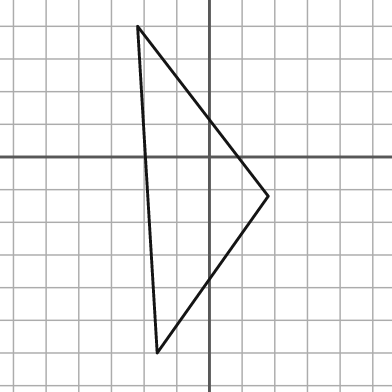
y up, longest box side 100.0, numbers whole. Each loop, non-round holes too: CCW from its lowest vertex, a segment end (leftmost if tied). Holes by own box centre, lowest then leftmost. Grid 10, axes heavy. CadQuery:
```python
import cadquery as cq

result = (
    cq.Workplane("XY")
    .moveTo(-16.0, -60.0)
    .lineTo(18.0, -12.0)
    .lineTo(-22.0, 40.0)
    .close()
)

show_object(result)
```